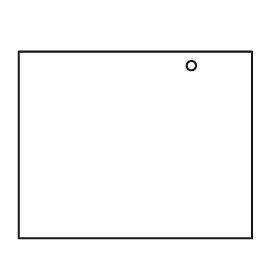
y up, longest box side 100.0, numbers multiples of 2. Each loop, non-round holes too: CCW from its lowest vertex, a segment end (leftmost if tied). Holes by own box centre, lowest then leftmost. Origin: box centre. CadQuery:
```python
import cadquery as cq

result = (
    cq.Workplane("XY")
    .moveTo(-50.0, -40.0)
    .lineTo(50.0, -40.0)
    .lineTo(50.0, 40.0)
    .lineTo(-50.0, 40.0)
    .close()
    .moveTo(24.0, 34.0)
    .circle(2.0)
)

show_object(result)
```